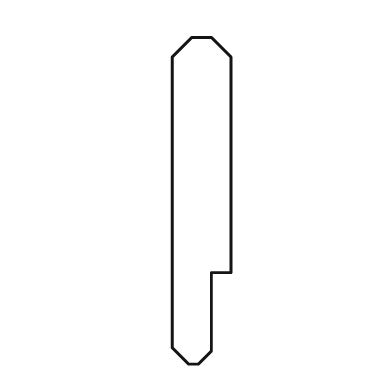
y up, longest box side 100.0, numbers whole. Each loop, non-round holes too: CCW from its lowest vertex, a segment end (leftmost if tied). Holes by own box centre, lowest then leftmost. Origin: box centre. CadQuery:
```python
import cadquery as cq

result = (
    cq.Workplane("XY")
    .moveTo(-4.0, -50.0)
    .lineTo(-1.0, -50.0)
    .lineTo(3.0, -46.0)
    .lineTo(3.0, -22.0)
    .lineTo(9.0, -22.0)
    .lineTo(9.0, 44.0)
    .lineTo(3.0, 50.0)
    .lineTo(-3.0, 50.0)
    .lineTo(-9.0, 44.0)
    .lineTo(-9.0, -45.0)
    .close()
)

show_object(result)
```